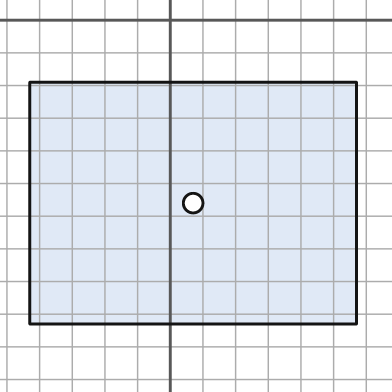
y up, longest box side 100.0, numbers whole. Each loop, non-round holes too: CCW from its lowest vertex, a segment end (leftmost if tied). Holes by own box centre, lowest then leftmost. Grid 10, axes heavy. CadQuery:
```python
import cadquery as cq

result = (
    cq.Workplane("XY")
    .moveTo(-43.0, -93.0)
    .lineTo(57.0, -93.0)
    .lineTo(57.0, -19.0)
    .lineTo(-43.0, -19.0)
    .close()
    .moveTo(7.0, -56.0)
    .circle(3.0)
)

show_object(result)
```